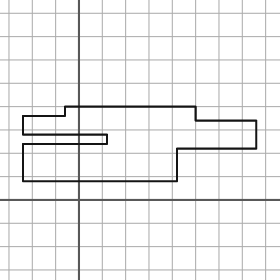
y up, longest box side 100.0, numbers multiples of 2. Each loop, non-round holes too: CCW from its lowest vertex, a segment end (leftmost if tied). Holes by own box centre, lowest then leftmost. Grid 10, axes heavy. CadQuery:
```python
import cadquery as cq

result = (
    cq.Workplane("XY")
    .moveTo(-24.0, 8.0)
    .lineTo(42.0, 8.0)
    .lineTo(42.0, 22.0)
    .lineTo(76.0, 22.0)
    .lineTo(76.0, 34.0)
    .lineTo(50.0, 34.0)
    .lineTo(50.0, 40.0)
    .lineTo(-6.0, 40.0)
    .lineTo(-6.0, 36.0)
    .lineTo(-24.0, 36.0)
    .lineTo(-24.0, 28.0)
    .lineTo(12.0, 28.0)
    .lineTo(12.0, 24.0)
    .lineTo(-24.0, 24.0)
    .close()
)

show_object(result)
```